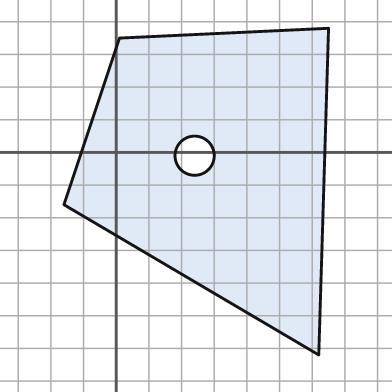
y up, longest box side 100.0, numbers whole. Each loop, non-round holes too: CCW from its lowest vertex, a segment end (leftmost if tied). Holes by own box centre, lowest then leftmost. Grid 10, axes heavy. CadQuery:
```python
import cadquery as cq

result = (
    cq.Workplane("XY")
    .moveTo(62.0, -62.0)
    .lineTo(65.0, 38.0)
    .lineTo(1.0, 35.0)
    .lineTo(-16.0, -16.0)
    .close()
    .moveTo(24.0, -1.0)
    .circle(6.0)
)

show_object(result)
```